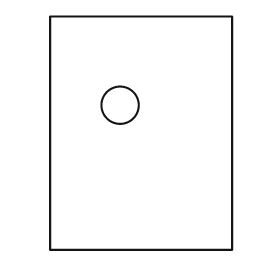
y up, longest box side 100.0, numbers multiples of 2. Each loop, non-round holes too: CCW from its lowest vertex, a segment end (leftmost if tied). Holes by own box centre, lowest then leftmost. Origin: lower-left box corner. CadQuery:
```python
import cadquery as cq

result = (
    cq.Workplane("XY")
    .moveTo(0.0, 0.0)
    .lineTo(78.0, 0.0)
    .lineTo(78.0, 100.0)
    .lineTo(0.0, 100.0)
    .close()
    .moveTo(30.0, 62.0)
    .circle(8.0)
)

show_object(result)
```